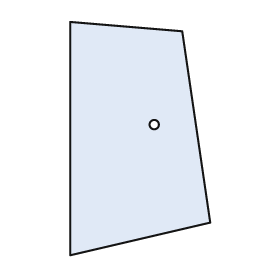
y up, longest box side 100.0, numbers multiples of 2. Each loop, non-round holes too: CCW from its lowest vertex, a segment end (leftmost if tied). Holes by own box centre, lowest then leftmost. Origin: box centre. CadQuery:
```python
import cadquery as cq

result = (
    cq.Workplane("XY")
    .moveTo(-30.0, -50.0)
    .lineTo(30.0, -36.0)
    .lineTo(18.0, 46.0)
    .lineTo(-30.0, 50.0)
    .close()
    .moveTo(6.0, 6.0)
    .circle(2.0)
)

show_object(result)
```